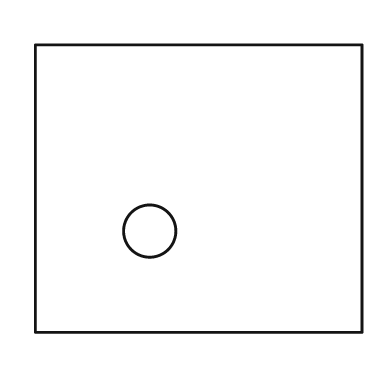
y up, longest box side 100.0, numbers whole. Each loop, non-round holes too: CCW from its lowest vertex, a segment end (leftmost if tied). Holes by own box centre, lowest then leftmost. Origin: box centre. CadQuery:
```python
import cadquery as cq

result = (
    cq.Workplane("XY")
    .moveTo(-50.0, -44.0)
    .lineTo(50.0, -44.0)
    .lineTo(50.0, 44.0)
    .lineTo(-50.0, 44.0)
    .close()
    .moveTo(-15.0, -13.0)
    .circle(8.0)
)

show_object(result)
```